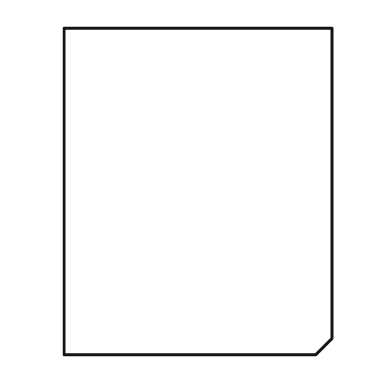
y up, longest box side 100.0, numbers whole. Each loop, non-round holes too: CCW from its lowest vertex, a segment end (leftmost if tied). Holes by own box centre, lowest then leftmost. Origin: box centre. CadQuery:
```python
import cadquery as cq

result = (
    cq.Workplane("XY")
    .moveTo(-41.0, -50.0)
    .lineTo(36.0, -50.0)
    .lineTo(41.0, -45.0)
    .lineTo(41.0, 50.0)
    .lineTo(-41.0, 50.0)
    .close()
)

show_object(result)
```